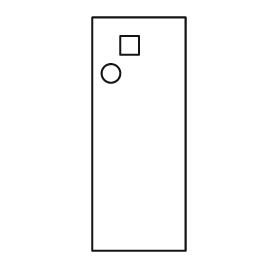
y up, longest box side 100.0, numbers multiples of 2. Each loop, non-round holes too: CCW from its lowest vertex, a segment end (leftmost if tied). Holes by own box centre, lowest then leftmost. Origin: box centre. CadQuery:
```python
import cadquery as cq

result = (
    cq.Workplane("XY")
    .moveTo(-20.0, -50.0)
    .lineTo(20.0, -50.0)
    .lineTo(20.0, 50.0)
    .lineTo(-20.0, 50.0)
    .close()
    .moveTo(-12.0, 26.0)
    .circle(4.0)
    .moveTo(-8.0, 34.0)
    .lineTo(0.0, 34.0)
    .lineTo(0.0, 42.0)
    .lineTo(-8.0, 42.0)
    .close()
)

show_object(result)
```